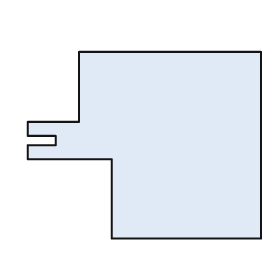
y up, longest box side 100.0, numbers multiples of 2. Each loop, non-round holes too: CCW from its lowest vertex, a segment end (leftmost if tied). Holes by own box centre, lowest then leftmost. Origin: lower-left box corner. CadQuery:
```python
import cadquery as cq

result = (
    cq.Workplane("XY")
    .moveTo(36.0, 0.0)
    .lineTo(100.0, 0.0)
    .lineTo(100.0, 80.0)
    .lineTo(22.0, 80.0)
    .lineTo(22.0, 50.0)
    .lineTo(0.0, 50.0)
    .lineTo(0.0, 44.0)
    .lineTo(12.0, 44.0)
    .lineTo(12.0, 40.0)
    .lineTo(0.0, 40.0)
    .lineTo(0.0, 34.0)
    .lineTo(36.0, 34.0)
    .close()
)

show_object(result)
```